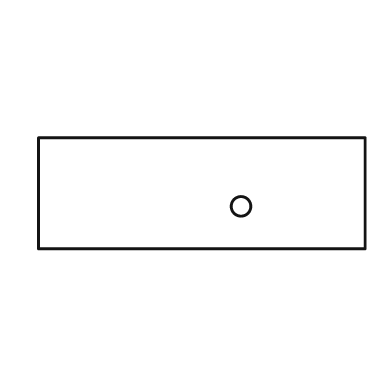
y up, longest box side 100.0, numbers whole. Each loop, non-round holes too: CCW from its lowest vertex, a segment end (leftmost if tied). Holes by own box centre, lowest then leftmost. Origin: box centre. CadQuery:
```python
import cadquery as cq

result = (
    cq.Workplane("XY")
    .moveTo(-50.0, -17.0)
    .lineTo(50.0, -17.0)
    .lineTo(50.0, 17.0)
    .lineTo(-50.0, 17.0)
    .close()
    .moveTo(12.0, -4.0)
    .circle(3.0)
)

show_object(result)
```